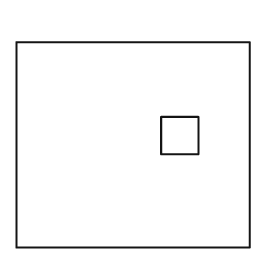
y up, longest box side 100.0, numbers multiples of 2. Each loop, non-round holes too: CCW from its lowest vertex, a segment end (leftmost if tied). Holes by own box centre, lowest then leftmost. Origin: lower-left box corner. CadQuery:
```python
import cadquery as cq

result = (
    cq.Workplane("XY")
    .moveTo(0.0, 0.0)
    .lineTo(100.0, 0.0)
    .lineTo(100.0, 88.0)
    .lineTo(0.0, 88.0)
    .close()
    .moveTo(62.0, 40.0)
    .lineTo(78.0, 40.0)
    .lineTo(78.0, 56.0)
    .lineTo(62.0, 56.0)
    .close()
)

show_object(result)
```